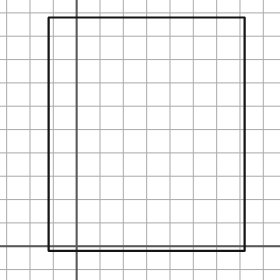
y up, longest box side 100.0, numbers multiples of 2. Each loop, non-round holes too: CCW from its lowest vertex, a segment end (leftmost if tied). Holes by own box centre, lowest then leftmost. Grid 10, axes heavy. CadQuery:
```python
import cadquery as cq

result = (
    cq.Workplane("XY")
    .moveTo(-12.0, -2.0)
    .lineTo(72.0, -2.0)
    .lineTo(72.0, 98.0)
    .lineTo(-12.0, 98.0)
    .close()
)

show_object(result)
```